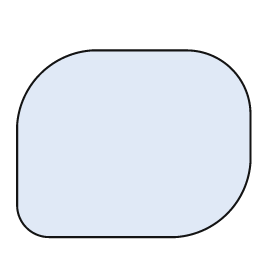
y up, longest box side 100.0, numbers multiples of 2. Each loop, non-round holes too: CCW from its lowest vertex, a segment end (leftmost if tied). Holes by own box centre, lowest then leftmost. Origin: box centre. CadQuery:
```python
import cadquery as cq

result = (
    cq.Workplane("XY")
    .moveTo(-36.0, -40.0)
    .lineTo(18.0, -40.0)
    .threePointArc((40.0, -30.0), (50.0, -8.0))
    .lineTo(50.0, 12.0)
    .threePointArc((42.0, 32.0), (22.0, 40.0))
    .lineTo(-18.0, 40.0)
    .threePointArc((-40.0, 30.0), (-50.0, 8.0))
    .lineTo(-50.0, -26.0)
    .threePointArc((-46.0, -36.0), (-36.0, -40.0))
    .close()
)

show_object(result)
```